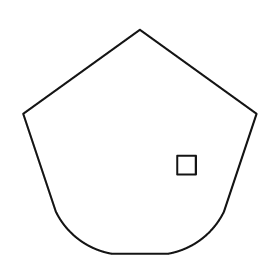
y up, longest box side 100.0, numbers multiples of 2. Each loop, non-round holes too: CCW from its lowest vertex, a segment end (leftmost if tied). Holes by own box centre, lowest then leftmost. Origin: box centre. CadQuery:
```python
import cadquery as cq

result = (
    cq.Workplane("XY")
    .moveTo(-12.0, -48.0)
    .lineTo(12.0, -48.0)
    .threePointArc((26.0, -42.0), (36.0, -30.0))
    .lineTo(50.0, 12.0)
    .lineTo(0.0, 48.0)
    .lineTo(-50.0, 12.0)
    .lineTo(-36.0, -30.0)
    .threePointArc((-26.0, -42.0), (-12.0, -48.0))
    .close()
    .moveTo(16.0, -14.0)
    .lineTo(24.0, -14.0)
    .lineTo(24.0, -6.0)
    .lineTo(16.0, -6.0)
    .close()
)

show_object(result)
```